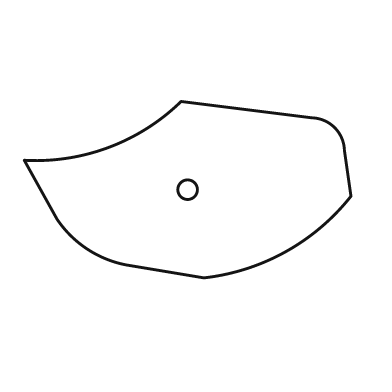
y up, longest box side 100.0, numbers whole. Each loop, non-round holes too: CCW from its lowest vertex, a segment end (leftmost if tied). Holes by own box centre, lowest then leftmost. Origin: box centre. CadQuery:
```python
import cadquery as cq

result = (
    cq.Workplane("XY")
    .moveTo(5.0, -27.0)
    .threePointArc((30.0, -19.0), (50.0, -2.0))
    .lineTo(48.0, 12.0)
    .threePointArc((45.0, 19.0), (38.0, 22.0))
    .lineTo(-2.0, 27.0)
    .threePointArc((-24.0, 13.0), (-50.0, 9.0))
    .lineTo(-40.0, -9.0)
    .threePointArc((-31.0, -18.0), (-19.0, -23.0))
    .close()
    .moveTo(0.0, 0.0)
    .circle(3.0)
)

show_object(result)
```